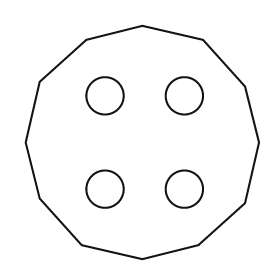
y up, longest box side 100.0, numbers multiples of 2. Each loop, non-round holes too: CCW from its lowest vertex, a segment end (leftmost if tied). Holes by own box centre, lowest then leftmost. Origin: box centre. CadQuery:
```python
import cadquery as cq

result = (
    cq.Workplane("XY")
    .moveTo(0.0, -50.0)
    .lineTo(24.0, -44.0)
    .lineTo(44.0, -26.0)
    .lineTo(50.0, 0.0)
    .lineTo(44.0, 24.0)
    .lineTo(26.0, 44.0)
    .lineTo(0.0, 50.0)
    .lineTo(-24.0, 44.0)
    .lineTo(-44.0, 26.0)
    .lineTo(-50.0, 0.0)
    .lineTo(-44.0, -24.0)
    .lineTo(-26.0, -44.0)
    .close()
    .moveTo(-16.0, -20.0)
    .circle(8.0)
    .moveTo(18.0, -20.0)
    .circle(8.0)
    .moveTo(-16.0, 20.0)
    .circle(8.0)
    .moveTo(18.0, 20.0)
    .circle(8.0)
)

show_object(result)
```